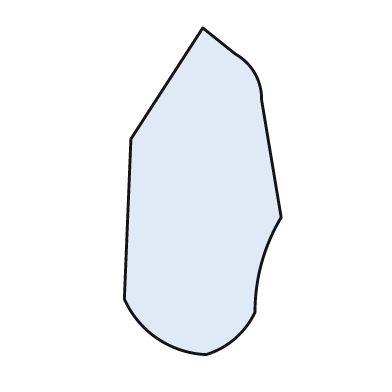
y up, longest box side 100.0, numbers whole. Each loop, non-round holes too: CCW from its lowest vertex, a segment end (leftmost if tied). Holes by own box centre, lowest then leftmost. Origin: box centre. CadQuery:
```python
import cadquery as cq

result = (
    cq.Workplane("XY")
    .moveTo(1.0, -50.0)
    .threePointArc((10.0, -45.0), (16.0, -37.0))
    .threePointArc((18.0, -22.0), (24.0, -8.0))
    .lineTo(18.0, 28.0)
    .threePointArc((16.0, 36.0), (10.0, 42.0))
    .lineTo(0.0, 50.0)
    .lineTo(-22.0, 16.0)
    .lineTo(-24.0, -33.0)
    .threePointArc((-14.0, -45.0), (1.0, -50.0))
    .close()
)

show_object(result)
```